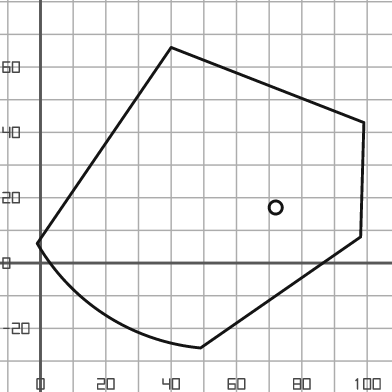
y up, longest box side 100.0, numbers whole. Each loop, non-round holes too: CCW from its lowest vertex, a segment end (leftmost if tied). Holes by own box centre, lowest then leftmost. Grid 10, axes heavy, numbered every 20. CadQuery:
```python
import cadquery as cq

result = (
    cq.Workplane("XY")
    .moveTo(49.0, -26.0)
    .lineTo(98.0, 8.0)
    .lineTo(99.0, 43.0)
    .lineTo(40.0, 66.0)
    .lineTo(-1.0, 6.0)
    .threePointArc((20.0, -16.0), (49.0, -26.0))
    .close()
    .moveTo(72.0, 17.0)
    .circle(2.0)
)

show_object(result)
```